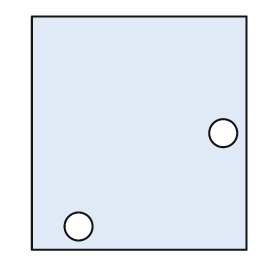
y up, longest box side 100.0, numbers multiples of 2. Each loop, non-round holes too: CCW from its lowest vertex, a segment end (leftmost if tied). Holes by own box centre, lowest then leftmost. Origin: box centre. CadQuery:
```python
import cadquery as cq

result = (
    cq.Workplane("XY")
    .moveTo(-46.0, -50.0)
    .lineTo(46.0, -50.0)
    .lineTo(46.0, 50.0)
    .lineTo(-46.0, 50.0)
    .close()
    .moveTo(-26.0, -40.0)
    .circle(6.0)
    .moveTo(36.0, 0.0)
    .circle(6.0)
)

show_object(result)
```